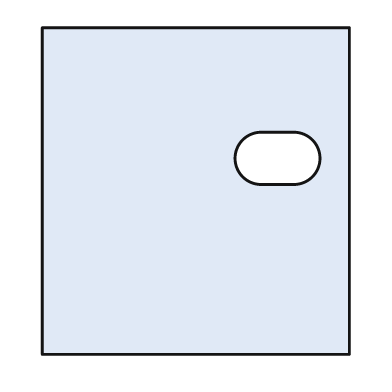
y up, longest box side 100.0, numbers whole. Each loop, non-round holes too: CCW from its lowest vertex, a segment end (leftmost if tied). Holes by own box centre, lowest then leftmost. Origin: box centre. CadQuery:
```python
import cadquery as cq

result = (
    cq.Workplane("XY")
    .moveTo(-47.0, -50.0)
    .lineTo(47.0, -50.0)
    .lineTo(47.0, 50.0)
    .lineTo(-47.0, 50.0)
    .close()
    .moveTo(20.0, 2.0)
    .lineTo(30.0, 2.0)
    .threePointArc((38.0, 10.0), (30.0, 18.0))
    .lineTo(20.0, 18.0)
    .threePointArc((12.0, 10.0), (20.0, 2.0))
    .close()
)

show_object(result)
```